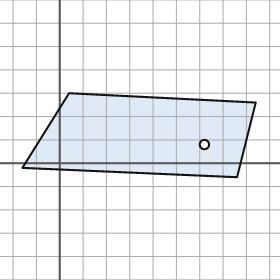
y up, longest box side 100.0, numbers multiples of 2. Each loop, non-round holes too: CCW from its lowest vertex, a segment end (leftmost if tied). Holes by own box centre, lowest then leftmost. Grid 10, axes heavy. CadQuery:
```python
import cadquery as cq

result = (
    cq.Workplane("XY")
    .moveTo(76.0, -6.0)
    .lineTo(84.0, 26.0)
    .lineTo(4.0, 30.0)
    .lineTo(-16.0, -2.0)
    .close()
    .moveTo(62.0, 8.0)
    .circle(2.0)
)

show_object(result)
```